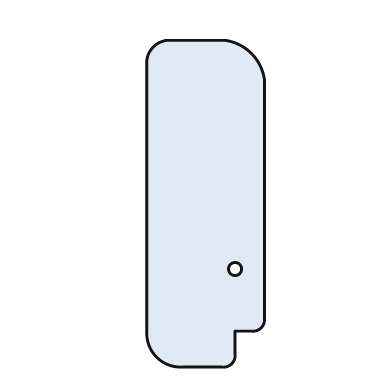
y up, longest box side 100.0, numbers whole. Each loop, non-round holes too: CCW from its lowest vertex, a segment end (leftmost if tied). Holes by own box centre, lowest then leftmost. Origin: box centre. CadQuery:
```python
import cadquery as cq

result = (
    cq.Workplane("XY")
    .moveTo(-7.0, -50.0)
    .lineTo(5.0, -50.0)
    .threePointArc((8.0, -49.0), (9.0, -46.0))
    .lineTo(9.0, -39.0)
    .lineTo(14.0, -39.0)
    .threePointArc((17.0, -38.0), (18.0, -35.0))
    .lineTo(18.0, 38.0)
    .threePointArc((14.0, 46.0), (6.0, 50.0))
    .lineTo(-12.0, 50.0)
    .threePointArc((-16.0, 48.0), (-18.0, 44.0))
    .lineTo(-18.0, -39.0)
    .threePointArc((-15.0, -47.0), (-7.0, -50.0))
    .close()
    .moveTo(9.0, -20.0)
    .circle(2.0)
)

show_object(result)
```